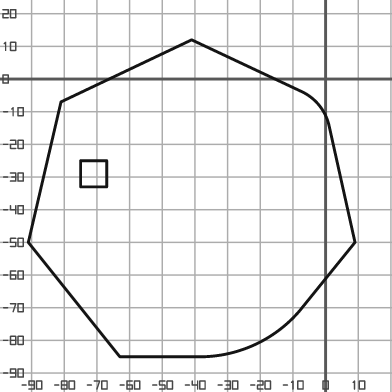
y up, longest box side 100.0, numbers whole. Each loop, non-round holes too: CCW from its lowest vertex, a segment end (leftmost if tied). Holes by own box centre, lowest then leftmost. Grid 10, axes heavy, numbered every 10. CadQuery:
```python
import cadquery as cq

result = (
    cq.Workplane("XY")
    .moveTo(-63.0, -85.0)
    .lineTo(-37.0, -85.0)
    .threePointArc((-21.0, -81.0), (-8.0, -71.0))
    .lineTo(9.0, -50.0)
    .lineTo(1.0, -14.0)
    .threePointArc((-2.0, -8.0), (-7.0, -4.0))
    .lineTo(-41.0, 12.0)
    .lineTo(-81.0, -7.0)
    .lineTo(-91.0, -50.0)
    .close()
    .moveTo(-75.0, -33.0)
    .lineTo(-67.0, -33.0)
    .lineTo(-67.0, -25.0)
    .lineTo(-75.0, -25.0)
    .close()
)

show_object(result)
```